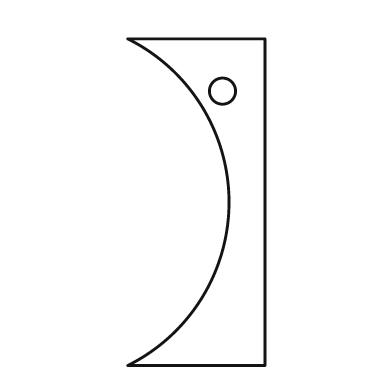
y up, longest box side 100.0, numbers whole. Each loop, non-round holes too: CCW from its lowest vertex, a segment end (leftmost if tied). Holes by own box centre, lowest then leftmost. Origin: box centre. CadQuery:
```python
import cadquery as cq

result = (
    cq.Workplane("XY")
    .moveTo(-21.0, -50.0)
    .lineTo(21.0, -50.0)
    .lineTo(21.0, 50.0)
    .lineTo(-21.0, 50.0)
    .threePointArc((10.0, 0.0), (-21.0, -50.0))
    .close()
    .moveTo(8.0, 34.0)
    .circle(4.0)
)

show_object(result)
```